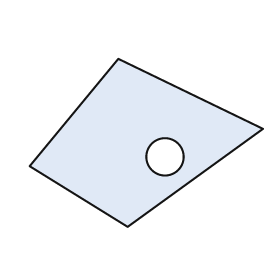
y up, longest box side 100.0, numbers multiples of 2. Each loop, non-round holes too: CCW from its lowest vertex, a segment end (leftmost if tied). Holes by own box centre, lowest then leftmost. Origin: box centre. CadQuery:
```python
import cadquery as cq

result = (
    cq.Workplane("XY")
    .moveTo(-8.0, -36.0)
    .lineTo(50.0, 6.0)
    .lineTo(-12.0, 36.0)
    .lineTo(-50.0, -10.0)
    .close()
    .moveTo(8.0, -6.0)
    .circle(8.0)
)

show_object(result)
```